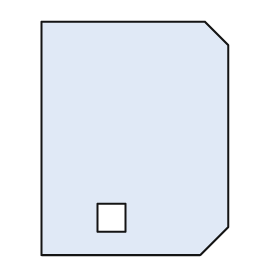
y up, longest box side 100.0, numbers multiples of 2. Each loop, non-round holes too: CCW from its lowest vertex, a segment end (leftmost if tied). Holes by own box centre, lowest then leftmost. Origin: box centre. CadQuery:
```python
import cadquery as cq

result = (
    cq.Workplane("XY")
    .moveTo(-40.0, -50.0)
    .lineTo(28.0, -50.0)
    .lineTo(40.0, -38.0)
    .lineTo(40.0, 40.0)
    .lineTo(30.0, 50.0)
    .lineTo(-40.0, 50.0)
    .close()
    .moveTo(-16.0, -40.0)
    .lineTo(-4.0, -40.0)
    .lineTo(-4.0, -28.0)
    .lineTo(-16.0, -28.0)
    .close()
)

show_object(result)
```